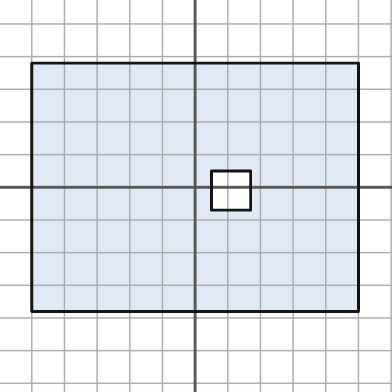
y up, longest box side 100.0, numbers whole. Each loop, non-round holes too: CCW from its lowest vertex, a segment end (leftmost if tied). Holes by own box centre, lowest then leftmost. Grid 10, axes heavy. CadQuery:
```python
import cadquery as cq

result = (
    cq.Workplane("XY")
    .moveTo(-50.0, -38.0)
    .lineTo(50.0, -38.0)
    .lineTo(50.0, 38.0)
    .lineTo(-50.0, 38.0)
    .close()
    .moveTo(5.0, -7.0)
    .lineTo(17.0, -7.0)
    .lineTo(17.0, 5.0)
    .lineTo(5.0, 5.0)
    .close()
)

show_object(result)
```